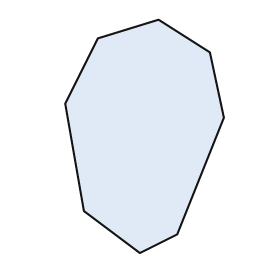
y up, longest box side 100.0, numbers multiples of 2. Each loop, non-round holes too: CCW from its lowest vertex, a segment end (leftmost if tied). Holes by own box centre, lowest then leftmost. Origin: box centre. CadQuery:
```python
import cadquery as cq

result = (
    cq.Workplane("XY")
    .moveTo(-2.0, -50.0)
    .lineTo(14.0, -42.0)
    .lineTo(34.0, 8.0)
    .lineTo(28.0, 36.0)
    .lineTo(6.0, 50.0)
    .lineTo(-20.0, 42.0)
    .lineTo(-34.0, 14.0)
    .lineTo(-26.0, -32.0)
    .close()
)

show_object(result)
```